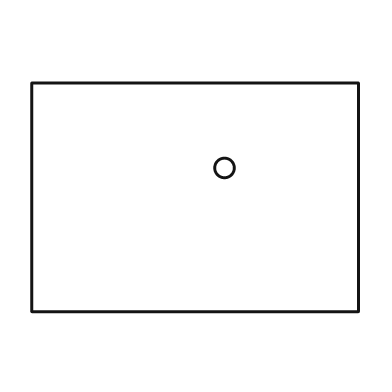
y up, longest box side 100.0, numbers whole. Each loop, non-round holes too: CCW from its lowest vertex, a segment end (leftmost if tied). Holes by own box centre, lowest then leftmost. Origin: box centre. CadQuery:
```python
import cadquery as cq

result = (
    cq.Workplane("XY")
    .moveTo(-50.0, -35.0)
    .lineTo(50.0, -35.0)
    .lineTo(50.0, 35.0)
    .lineTo(-50.0, 35.0)
    .close()
    .moveTo(9.0, 9.0)
    .circle(3.0)
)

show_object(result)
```